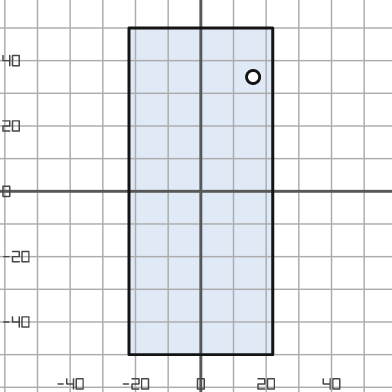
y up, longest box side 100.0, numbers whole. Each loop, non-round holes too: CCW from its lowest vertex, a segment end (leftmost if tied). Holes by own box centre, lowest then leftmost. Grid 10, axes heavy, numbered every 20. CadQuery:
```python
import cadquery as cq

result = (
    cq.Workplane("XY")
    .moveTo(-22.0, -50.0)
    .lineTo(22.0, -50.0)
    .lineTo(22.0, 50.0)
    .lineTo(-22.0, 50.0)
    .close()
    .moveTo(16.0, 35.0)
    .circle(2.0)
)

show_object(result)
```